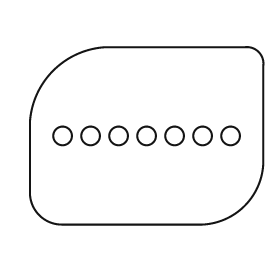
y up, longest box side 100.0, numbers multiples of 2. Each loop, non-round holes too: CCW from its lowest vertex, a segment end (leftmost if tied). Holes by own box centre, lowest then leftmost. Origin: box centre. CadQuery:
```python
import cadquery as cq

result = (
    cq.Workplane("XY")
    .moveTo(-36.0, -38.0)
    .lineTo(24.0, -38.0)
    .threePointArc((42.0, -30.0), (50.0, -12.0))
    .lineTo(50.0, 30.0)
    .threePointArc((48.0, 36.0), (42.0, 38.0))
    .lineTo(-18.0, 38.0)
    .threePointArc((-40.0, 28.0), (-50.0, 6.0))
    .lineTo(-50.0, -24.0)
    .threePointArc((-46.0, -34.0), (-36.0, -38.0))
    .close()
    .moveTo(-36.0, 0.0)
    .circle(4.0)
    .moveTo(-24.0, 0.0)
    .circle(4.0)
    .moveTo(-12.0, 0.0)
    .circle(4.0)
    .moveTo(0.0, 0.0)
    .circle(4.0)
    .moveTo(12.0, 0.0)
    .circle(4.0)
    .moveTo(24.0, 0.0)
    .circle(4.0)
    .moveTo(36.0, 0.0)
    .circle(4.0)
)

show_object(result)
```